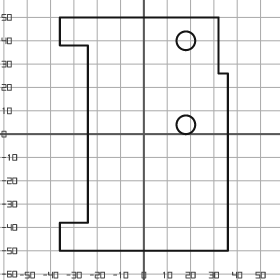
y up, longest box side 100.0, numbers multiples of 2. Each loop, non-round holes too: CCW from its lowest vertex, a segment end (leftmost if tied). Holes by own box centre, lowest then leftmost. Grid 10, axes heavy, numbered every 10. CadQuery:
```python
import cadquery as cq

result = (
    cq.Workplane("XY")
    .moveTo(-36.0, -50.0)
    .lineTo(36.0, -50.0)
    .lineTo(36.0, 26.0)
    .lineTo(32.0, 26.0)
    .lineTo(32.0, 50.0)
    .lineTo(-36.0, 50.0)
    .lineTo(-36.0, 38.0)
    .lineTo(-24.0, 38.0)
    .lineTo(-24.0, -38.0)
    .lineTo(-36.0, -38.0)
    .close()
    .moveTo(18.0, 4.0)
    .circle(4.0)
    .moveTo(18.0, 40.0)
    .circle(4.0)
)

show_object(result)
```